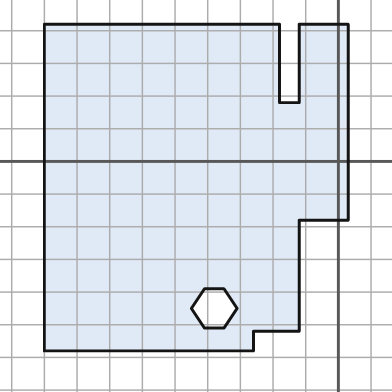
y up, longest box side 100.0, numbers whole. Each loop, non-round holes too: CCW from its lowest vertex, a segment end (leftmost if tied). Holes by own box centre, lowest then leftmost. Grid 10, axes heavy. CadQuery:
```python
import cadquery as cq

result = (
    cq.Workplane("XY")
    .moveTo(-90.0, -58.0)
    .lineTo(-26.0, -58.0)
    .lineTo(-26.0, -52.0)
    .lineTo(-12.0, -52.0)
    .lineTo(-12.0, -18.0)
    .lineTo(3.0, -18.0)
    .lineTo(3.0, 42.0)
    .lineTo(-12.0, 42.0)
    .lineTo(-12.0, 18.0)
    .lineTo(-18.0, 18.0)
    .lineTo(-18.0, 42.0)
    .lineTo(-90.0, 42.0)
    .close()
    .moveTo(-41.0, -51.0)
    .lineTo(-35.0, -51.0)
    .lineTo(-31.0, -45.0)
    .lineTo(-35.0, -39.0)
    .lineTo(-41.0, -39.0)
    .lineTo(-45.0, -45.0)
    .close()
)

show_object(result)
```